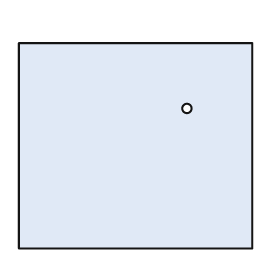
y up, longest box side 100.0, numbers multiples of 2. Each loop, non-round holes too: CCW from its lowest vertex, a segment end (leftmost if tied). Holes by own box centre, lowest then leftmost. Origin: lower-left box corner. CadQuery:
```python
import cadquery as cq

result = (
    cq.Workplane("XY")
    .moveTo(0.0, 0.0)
    .lineTo(100.0, 0.0)
    .lineTo(100.0, 88.0)
    .lineTo(0.0, 88.0)
    .close()
    .moveTo(72.0, 60.0)
    .circle(2.0)
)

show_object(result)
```